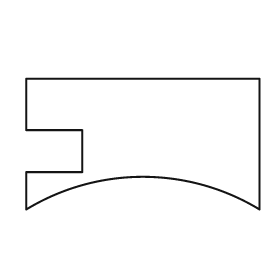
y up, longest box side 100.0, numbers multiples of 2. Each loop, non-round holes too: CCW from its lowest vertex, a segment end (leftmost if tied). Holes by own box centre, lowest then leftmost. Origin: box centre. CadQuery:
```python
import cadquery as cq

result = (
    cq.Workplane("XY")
    .moveTo(-50.0, -28.0)
    .threePointArc((0.0, -14.0), (50.0, -28.0))
    .lineTo(50.0, 28.0)
    .lineTo(-50.0, 28.0)
    .lineTo(-50.0, 6.0)
    .lineTo(-26.0, 6.0)
    .lineTo(-26.0, -12.0)
    .lineTo(-50.0, -12.0)
    .close()
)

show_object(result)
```